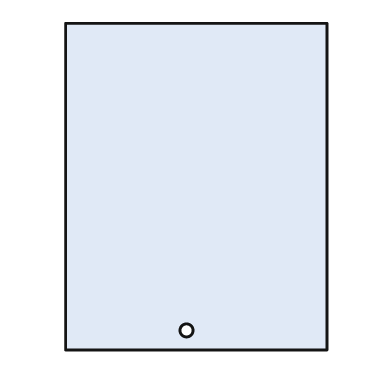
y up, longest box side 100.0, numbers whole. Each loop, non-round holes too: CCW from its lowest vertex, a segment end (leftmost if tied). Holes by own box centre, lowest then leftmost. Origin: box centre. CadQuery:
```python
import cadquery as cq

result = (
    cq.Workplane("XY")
    .moveTo(-40.0, -50.0)
    .lineTo(40.0, -50.0)
    .lineTo(40.0, 50.0)
    .lineTo(-40.0, 50.0)
    .close()
    .moveTo(-3.0, -44.0)
    .circle(2.0)
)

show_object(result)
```